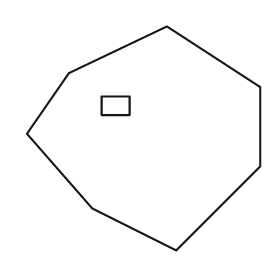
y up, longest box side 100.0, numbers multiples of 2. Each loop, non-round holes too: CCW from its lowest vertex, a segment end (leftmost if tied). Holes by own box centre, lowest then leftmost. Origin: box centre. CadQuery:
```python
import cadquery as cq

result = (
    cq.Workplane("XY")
    .moveTo(14.0, -48.0)
    .lineTo(50.0, -12.0)
    .lineTo(50.0, 22.0)
    .lineTo(10.0, 48.0)
    .lineTo(-32.0, 28.0)
    .lineTo(-50.0, 2.0)
    .lineTo(-22.0, -30.0)
    .close()
    .moveTo(-18.0, 10.0)
    .lineTo(-6.0, 10.0)
    .lineTo(-6.0, 18.0)
    .lineTo(-18.0, 18.0)
    .close()
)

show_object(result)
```